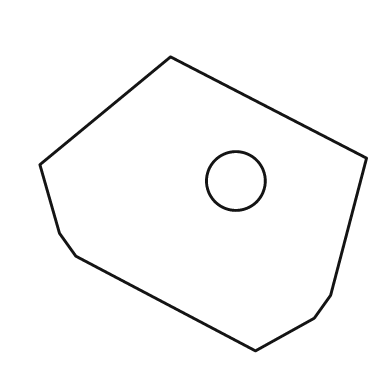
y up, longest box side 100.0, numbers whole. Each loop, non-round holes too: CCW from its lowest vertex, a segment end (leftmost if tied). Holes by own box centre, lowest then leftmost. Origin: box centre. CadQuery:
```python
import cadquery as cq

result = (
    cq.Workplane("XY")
    .moveTo(16.0, -45.0)
    .lineTo(34.0, -35.0)
    .lineTo(39.0, -28.0)
    .lineTo(50.0, 14.0)
    .lineTo(-10.0, 45.0)
    .lineTo(-50.0, 12.0)
    .lineTo(-44.0, -9.0)
    .lineTo(-39.0, -16.0)
    .close()
    .moveTo(10.0, 7.0)
    .circle(9.0)
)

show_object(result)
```